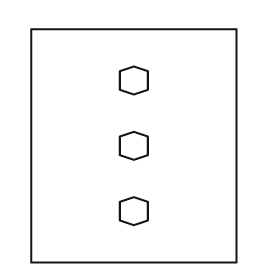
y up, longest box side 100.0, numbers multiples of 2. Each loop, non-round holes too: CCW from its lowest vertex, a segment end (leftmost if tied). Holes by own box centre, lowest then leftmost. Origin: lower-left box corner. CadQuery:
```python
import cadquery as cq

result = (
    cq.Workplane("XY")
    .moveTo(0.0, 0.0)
    .lineTo(88.0, 0.0)
    .lineTo(88.0, 100.0)
    .lineTo(0.0, 100.0)
    .close()
    .moveTo(44.0, 16.0)
    .lineTo(50.0, 18.0)
    .lineTo(50.0, 26.0)
    .lineTo(44.0, 28.0)
    .lineTo(38.0, 26.0)
    .lineTo(38.0, 18.0)
    .close()
    .moveTo(44.0, 44.0)
    .lineTo(50.0, 46.0)
    .lineTo(50.0, 54.0)
    .lineTo(44.0, 56.0)
    .lineTo(38.0, 54.0)
    .lineTo(38.0, 46.0)
    .close()
    .moveTo(44.0, 72.0)
    .lineTo(50.0, 74.0)
    .lineTo(50.0, 82.0)
    .lineTo(44.0, 84.0)
    .lineTo(38.0, 82.0)
    .lineTo(38.0, 74.0)
    .close()
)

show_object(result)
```